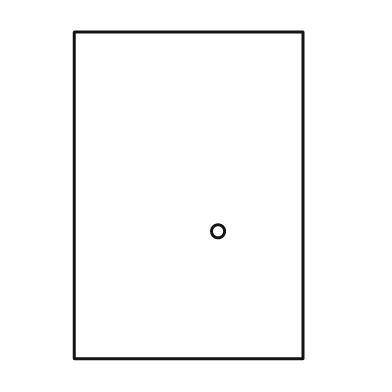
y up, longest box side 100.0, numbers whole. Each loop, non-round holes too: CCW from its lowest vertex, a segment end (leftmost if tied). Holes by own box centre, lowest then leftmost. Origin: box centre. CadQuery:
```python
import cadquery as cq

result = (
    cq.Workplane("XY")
    .moveTo(-35.0, -50.0)
    .lineTo(35.0, -50.0)
    .lineTo(35.0, 50.0)
    .lineTo(-35.0, 50.0)
    .close()
    .moveTo(9.0, -11.0)
    .circle(2.0)
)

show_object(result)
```